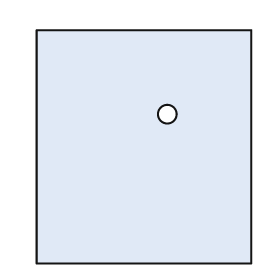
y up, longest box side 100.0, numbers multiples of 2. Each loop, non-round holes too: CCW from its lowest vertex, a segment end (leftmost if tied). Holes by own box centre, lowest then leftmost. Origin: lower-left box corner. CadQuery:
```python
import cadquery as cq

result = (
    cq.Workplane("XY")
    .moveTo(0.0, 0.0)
    .lineTo(92.0, 0.0)
    .lineTo(92.0, 100.0)
    .lineTo(0.0, 100.0)
    .close()
    .moveTo(56.0, 64.0)
    .circle(4.0)
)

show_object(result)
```